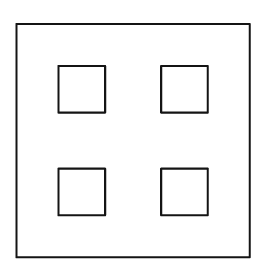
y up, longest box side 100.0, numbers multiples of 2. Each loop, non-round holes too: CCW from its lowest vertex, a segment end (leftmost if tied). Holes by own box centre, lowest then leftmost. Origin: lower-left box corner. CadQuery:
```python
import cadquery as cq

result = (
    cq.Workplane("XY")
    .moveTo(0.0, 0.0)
    .lineTo(100.0, 0.0)
    .lineTo(100.0, 100.0)
    .lineTo(0.0, 100.0)
    .close()
    .moveTo(18.0, 18.0)
    .lineTo(38.0, 18.0)
    .lineTo(38.0, 38.0)
    .lineTo(18.0, 38.0)
    .close()
    .moveTo(62.0, 18.0)
    .lineTo(82.0, 18.0)
    .lineTo(82.0, 38.0)
    .lineTo(62.0, 38.0)
    .close()
    .moveTo(18.0, 62.0)
    .lineTo(38.0, 62.0)
    .lineTo(38.0, 82.0)
    .lineTo(18.0, 82.0)
    .close()
    .moveTo(62.0, 62.0)
    .lineTo(82.0, 62.0)
    .lineTo(82.0, 82.0)
    .lineTo(62.0, 82.0)
    .close()
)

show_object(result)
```